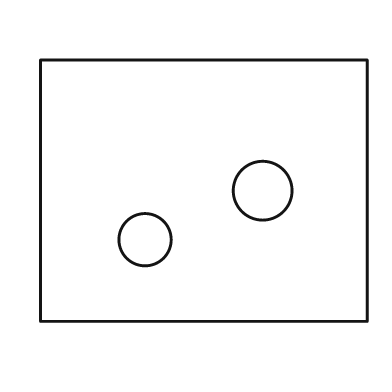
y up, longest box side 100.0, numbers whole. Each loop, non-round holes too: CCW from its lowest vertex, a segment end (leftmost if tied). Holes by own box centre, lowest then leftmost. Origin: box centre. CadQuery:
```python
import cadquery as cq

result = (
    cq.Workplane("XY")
    .moveTo(-50.0, -40.0)
    .lineTo(50.0, -40.0)
    .lineTo(50.0, 40.0)
    .lineTo(-50.0, 40.0)
    .close()
    .moveTo(-18.0, -15.0)
    .circle(8.0)
    .moveTo(18.0, 0.0)
    .circle(9.0)
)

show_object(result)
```